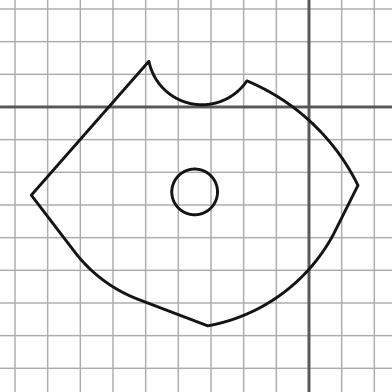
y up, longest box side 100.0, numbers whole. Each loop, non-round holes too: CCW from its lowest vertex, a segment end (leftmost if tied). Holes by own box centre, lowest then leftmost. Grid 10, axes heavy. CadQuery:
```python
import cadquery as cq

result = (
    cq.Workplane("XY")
    .moveTo(-31.0, -67.0)
    .threePointArc((-8.0, -57.0), (8.0, -38.0))
    .lineTo(15.0, -24.0)
    .threePointArc((1.0, -5.0), (-19.0, 8.0))
    .threePointArc((-36.0, 1.0), (-49.0, 14.0))
    .lineTo(-85.0, -27.0)
    .lineTo(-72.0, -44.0)
    .threePointArc((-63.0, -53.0), (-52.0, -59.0))
    .close()
    .moveTo(-35.0, -26.0)
    .circle(7.0)
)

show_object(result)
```